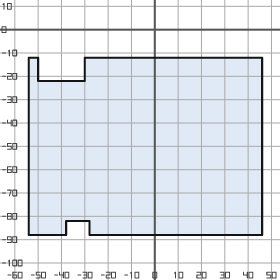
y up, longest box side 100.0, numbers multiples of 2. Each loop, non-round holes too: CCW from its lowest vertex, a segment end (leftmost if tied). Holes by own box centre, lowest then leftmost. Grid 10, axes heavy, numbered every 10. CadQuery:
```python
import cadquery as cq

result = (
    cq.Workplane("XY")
    .moveTo(-54.0, -88.0)
    .lineTo(-38.0, -88.0)
    .lineTo(-38.0, -82.0)
    .lineTo(-28.0, -82.0)
    .lineTo(-28.0, -88.0)
    .lineTo(46.0, -88.0)
    .lineTo(46.0, -12.0)
    .lineTo(-30.0, -12.0)
    .lineTo(-30.0, -22.0)
    .lineTo(-50.0, -22.0)
    .lineTo(-50.0, -12.0)
    .lineTo(-54.0, -12.0)
    .close()
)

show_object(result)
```